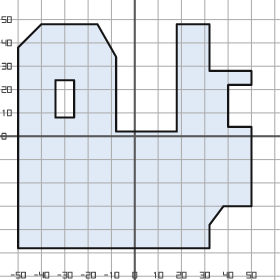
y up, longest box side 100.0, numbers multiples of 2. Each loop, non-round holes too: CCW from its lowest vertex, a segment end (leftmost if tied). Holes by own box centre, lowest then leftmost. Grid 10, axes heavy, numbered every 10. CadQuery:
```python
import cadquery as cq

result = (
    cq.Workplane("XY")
    .moveTo(-50.0, -48.0)
    .lineTo(32.0, -48.0)
    .lineTo(32.0, -38.0)
    .lineTo(38.0, -30.0)
    .lineTo(50.0, -30.0)
    .lineTo(50.0, 4.0)
    .lineTo(40.0, 4.0)
    .lineTo(40.0, 22.0)
    .lineTo(50.0, 22.0)
    .lineTo(50.0, 28.0)
    .lineTo(32.0, 28.0)
    .lineTo(32.0, 48.0)
    .lineTo(18.0, 48.0)
    .lineTo(18.0, 2.0)
    .lineTo(-8.0, 2.0)
    .lineTo(-8.0, 34.0)
    .lineTo(-16.0, 48.0)
    .lineTo(-40.0, 48.0)
    .lineTo(-50.0, 38.0)
    .close()
    .moveTo(-34.0, 8.0)
    .lineTo(-26.0, 8.0)
    .lineTo(-26.0, 24.0)
    .lineTo(-34.0, 24.0)
    .close()
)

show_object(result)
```